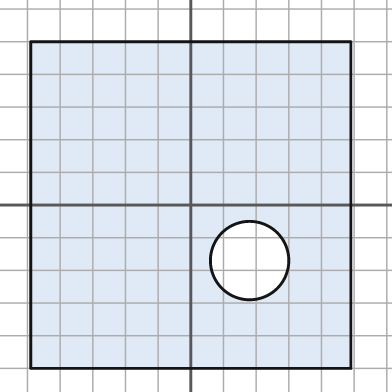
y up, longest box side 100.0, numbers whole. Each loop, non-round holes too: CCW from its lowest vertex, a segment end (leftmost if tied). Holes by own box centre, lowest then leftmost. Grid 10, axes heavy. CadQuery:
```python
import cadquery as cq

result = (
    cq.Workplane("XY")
    .moveTo(-49.0, -50.0)
    .lineTo(49.0, -50.0)
    .lineTo(49.0, 50.0)
    .lineTo(-49.0, 50.0)
    .close()
    .moveTo(18.0, -17.0)
    .circle(12.0)
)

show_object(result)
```